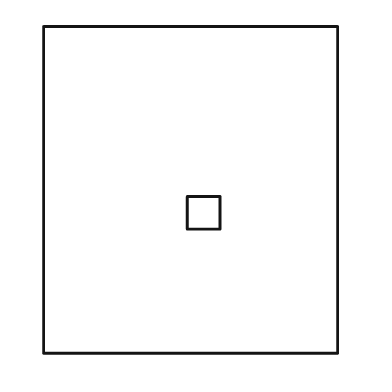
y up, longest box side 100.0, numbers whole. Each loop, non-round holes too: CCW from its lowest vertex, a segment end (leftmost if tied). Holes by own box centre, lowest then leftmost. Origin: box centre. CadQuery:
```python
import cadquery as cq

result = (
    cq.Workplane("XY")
    .moveTo(-45.0, -50.0)
    .lineTo(45.0, -50.0)
    .lineTo(45.0, 50.0)
    .lineTo(-45.0, 50.0)
    .close()
    .moveTo(-1.0, -12.0)
    .lineTo(9.0, -12.0)
    .lineTo(9.0, -2.0)
    .lineTo(-1.0, -2.0)
    .close()
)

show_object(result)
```